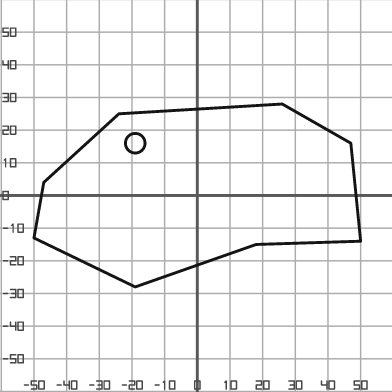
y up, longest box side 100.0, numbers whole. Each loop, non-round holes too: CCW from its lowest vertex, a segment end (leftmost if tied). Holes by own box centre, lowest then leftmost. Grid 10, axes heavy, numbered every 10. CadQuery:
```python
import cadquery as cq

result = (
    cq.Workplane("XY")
    .moveTo(-19.0, -28.0)
    .lineTo(18.0, -15.0)
    .lineTo(50.0, -14.0)
    .lineTo(47.0, 16.0)
    .lineTo(26.0, 28.0)
    .lineTo(-24.0, 25.0)
    .lineTo(-47.0, 4.0)
    .lineTo(-50.0, -13.0)
    .close()
    .moveTo(-19.0, 16.0)
    .circle(3.0)
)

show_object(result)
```